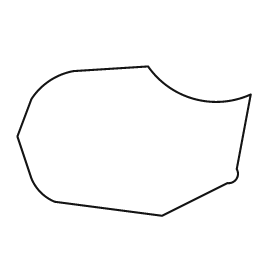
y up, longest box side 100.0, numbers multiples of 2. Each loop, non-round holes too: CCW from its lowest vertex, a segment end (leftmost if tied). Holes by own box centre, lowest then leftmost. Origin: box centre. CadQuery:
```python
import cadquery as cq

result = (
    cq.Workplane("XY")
    .moveTo(12.0, -32.0)
    .lineTo(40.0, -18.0)
    .threePointArc((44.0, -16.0), (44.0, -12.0))
    .lineTo(50.0, 20.0)
    .threePointArc((26.0, 18.0), (6.0, 32.0))
    .lineTo(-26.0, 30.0)
    .threePointArc((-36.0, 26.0), (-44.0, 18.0))
    .lineTo(-50.0, 2.0)
    .lineTo(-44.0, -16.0)
    .threePointArc((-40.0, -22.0), (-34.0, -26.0))
    .close()
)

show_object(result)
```